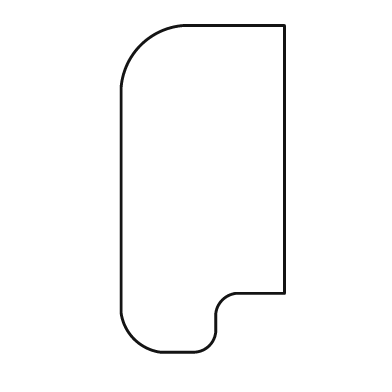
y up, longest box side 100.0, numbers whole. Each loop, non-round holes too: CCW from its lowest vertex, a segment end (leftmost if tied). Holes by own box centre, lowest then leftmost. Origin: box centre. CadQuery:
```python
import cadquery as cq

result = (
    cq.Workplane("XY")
    .moveTo(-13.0, -50.0)
    .lineTo(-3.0, -50.0)
    .threePointArc((2.0, -48.0), (4.0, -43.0))
    .lineTo(4.0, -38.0)
    .threePointArc((6.0, -34.0), (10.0, -32.0))
    .lineTo(25.0, -32.0)
    .lineTo(25.0, 50.0)
    .lineTo(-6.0, 50.0)
    .threePointArc((-19.0, 44.0), (-25.0, 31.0))
    .lineTo(-25.0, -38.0)
    .threePointArc((-21.0, -46.0), (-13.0, -50.0))
    .close()
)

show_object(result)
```